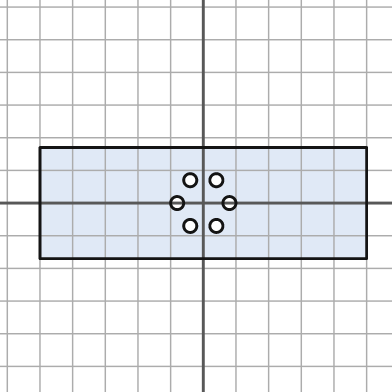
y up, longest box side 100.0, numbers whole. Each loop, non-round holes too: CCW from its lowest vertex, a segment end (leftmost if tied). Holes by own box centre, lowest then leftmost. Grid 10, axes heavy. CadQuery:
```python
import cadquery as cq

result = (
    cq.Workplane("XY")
    .moveTo(-50.0, -17.0)
    .lineTo(50.0, -17.0)
    .lineTo(50.0, 17.0)
    .lineTo(-50.0, 17.0)
    .close()
    .moveTo(-4.0, -7.0)
    .circle(2.0)
    .moveTo(4.0, -7.0)
    .circle(2.0)
    .moveTo(-8.0, 0.0)
    .circle(2.0)
    .moveTo(8.0, 0.0)
    .circle(2.0)
    .moveTo(-4.0, 7.0)
    .circle(2.0)
    .moveTo(4.0, 7.0)
    .circle(2.0)
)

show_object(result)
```